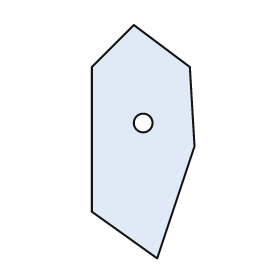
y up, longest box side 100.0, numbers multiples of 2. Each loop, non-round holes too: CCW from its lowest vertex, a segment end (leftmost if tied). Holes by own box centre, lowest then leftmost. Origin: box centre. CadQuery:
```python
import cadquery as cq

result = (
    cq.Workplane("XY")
    .moveTo(6.0, -50.0)
    .lineTo(22.0, -2.0)
    .lineTo(20.0, 32.0)
    .lineTo(-4.0, 50.0)
    .lineTo(-22.0, 32.0)
    .lineTo(-22.0, -30.0)
    .close()
    .moveTo(0.0, 8.0)
    .circle(4.0)
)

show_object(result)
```